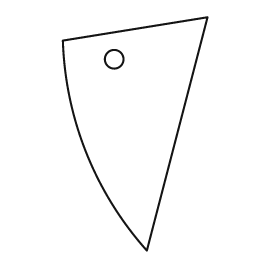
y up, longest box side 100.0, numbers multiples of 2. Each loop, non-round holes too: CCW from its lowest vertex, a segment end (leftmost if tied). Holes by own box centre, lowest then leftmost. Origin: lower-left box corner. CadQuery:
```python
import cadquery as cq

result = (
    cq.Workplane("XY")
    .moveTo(36.0, 0.0)
    .lineTo(62.0, 100.0)
    .lineTo(0.0, 90.0)
    .threePointArc((10.0, 42.0), (36.0, 0.0))
    .close()
    .moveTo(22.0, 82.0)
    .circle(4.0)
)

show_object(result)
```